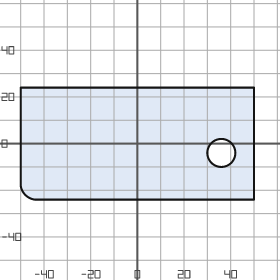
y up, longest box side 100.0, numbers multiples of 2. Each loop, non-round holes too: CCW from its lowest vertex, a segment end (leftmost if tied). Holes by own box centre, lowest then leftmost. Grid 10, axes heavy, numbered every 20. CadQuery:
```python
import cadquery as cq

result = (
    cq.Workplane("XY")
    .moveTo(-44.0, -24.0)
    .lineTo(50.0, -24.0)
    .lineTo(50.0, 24.0)
    .lineTo(-50.0, 24.0)
    .lineTo(-50.0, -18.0)
    .threePointArc((-48.0, -22.0), (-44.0, -24.0))
    .close()
    .moveTo(36.0, -4.0)
    .circle(6.0)
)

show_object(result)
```